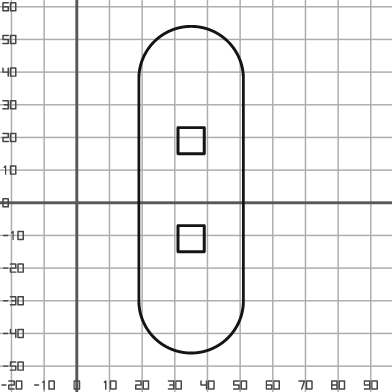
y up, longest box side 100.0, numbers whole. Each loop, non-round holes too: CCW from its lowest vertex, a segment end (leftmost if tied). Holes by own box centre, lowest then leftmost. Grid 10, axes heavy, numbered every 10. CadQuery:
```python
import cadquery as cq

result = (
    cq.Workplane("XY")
    .moveTo(19.0, -30.0)
    .threePointArc((35.0, -46.0), (51.0, -30.0))
    .lineTo(51.0, 38.0)
    .threePointArc((35.0, 54.0), (19.0, 38.0))
    .close()
    .moveTo(31.0, -15.0)
    .lineTo(39.0, -15.0)
    .lineTo(39.0, -7.0)
    .lineTo(31.0, -7.0)
    .close()
    .moveTo(31.0, 15.0)
    .lineTo(39.0, 15.0)
    .lineTo(39.0, 23.0)
    .lineTo(31.0, 23.0)
    .close()
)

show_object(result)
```